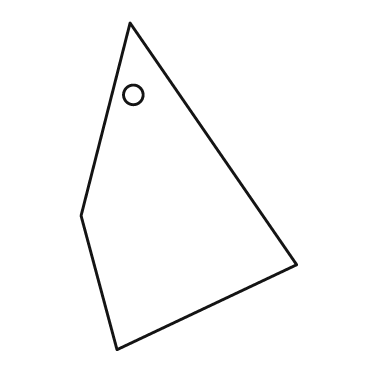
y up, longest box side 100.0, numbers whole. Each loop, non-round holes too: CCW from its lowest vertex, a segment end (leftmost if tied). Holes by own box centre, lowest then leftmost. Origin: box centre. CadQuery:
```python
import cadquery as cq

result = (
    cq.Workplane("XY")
    .moveTo(-22.0, -50.0)
    .lineTo(33.0, -24.0)
    .lineTo(-18.0, 50.0)
    .lineTo(-33.0, -9.0)
    .close()
    .moveTo(-17.0, 28.0)
    .circle(3.0)
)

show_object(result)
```